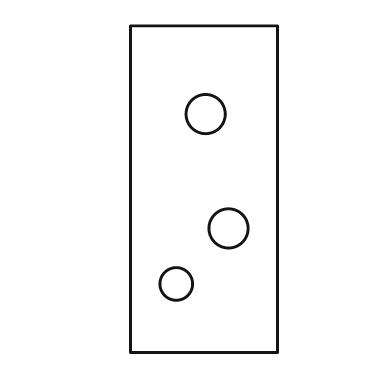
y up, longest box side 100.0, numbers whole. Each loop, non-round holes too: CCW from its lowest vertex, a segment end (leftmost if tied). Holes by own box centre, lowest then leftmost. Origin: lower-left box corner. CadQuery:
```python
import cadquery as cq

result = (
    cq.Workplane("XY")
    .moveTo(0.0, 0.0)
    .lineTo(45.0, 0.0)
    .lineTo(45.0, 100.0)
    .lineTo(0.0, 100.0)
    .close()
    .moveTo(14.0, 21.0)
    .circle(5.0)
    .moveTo(30.0, 38.0)
    .circle(6.0)
    .moveTo(23.0, 73.0)
    .circle(6.0)
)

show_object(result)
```